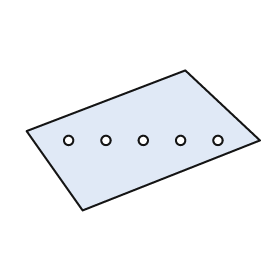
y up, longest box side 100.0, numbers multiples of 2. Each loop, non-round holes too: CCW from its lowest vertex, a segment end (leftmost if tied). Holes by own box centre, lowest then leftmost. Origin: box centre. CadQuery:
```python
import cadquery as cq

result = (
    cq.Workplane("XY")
    .moveTo(-26.0, -30.0)
    .lineTo(50.0, 0.0)
    .lineTo(18.0, 30.0)
    .lineTo(-50.0, 4.0)
    .close()
    .moveTo(-32.0, 0.0)
    .circle(2.0)
    .moveTo(-16.0, 0.0)
    .circle(2.0)
    .moveTo(0.0, 0.0)
    .circle(2.0)
    .moveTo(16.0, 0.0)
    .circle(2.0)
    .moveTo(32.0, 0.0)
    .circle(2.0)
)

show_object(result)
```